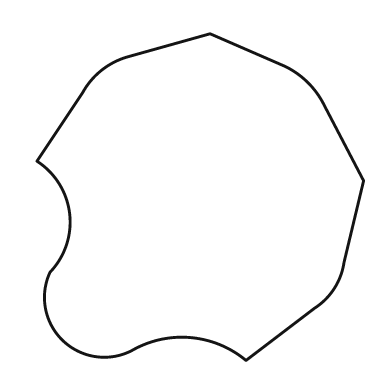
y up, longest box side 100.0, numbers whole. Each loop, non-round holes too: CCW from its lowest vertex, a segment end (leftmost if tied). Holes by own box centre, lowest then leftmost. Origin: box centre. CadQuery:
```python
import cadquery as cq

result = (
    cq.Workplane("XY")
    .moveTo(14.0, -50.0)
    .lineTo(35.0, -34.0)
    .threePointArc((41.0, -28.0), (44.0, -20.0))
    .lineTo(50.0, 5.0)
    .lineTo(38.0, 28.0)
    .threePointArc((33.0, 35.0), (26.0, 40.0))
    .lineTo(3.0, 50.0)
    .lineTo(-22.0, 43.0)
    .threePointArc((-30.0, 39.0), (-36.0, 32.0))
    .lineTo(-50.0, 11.0)
    .threePointArc((-40.0, -5.0), (-46.0, -23.0))
    .threePointArc((-42.0, -44.0), (-21.0, -47.0))
    .threePointArc((-3.0, -43.0), (14.0, -50.0))
    .close()
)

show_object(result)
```